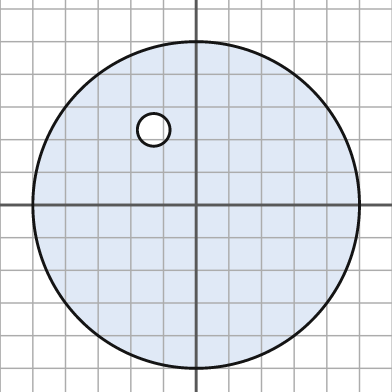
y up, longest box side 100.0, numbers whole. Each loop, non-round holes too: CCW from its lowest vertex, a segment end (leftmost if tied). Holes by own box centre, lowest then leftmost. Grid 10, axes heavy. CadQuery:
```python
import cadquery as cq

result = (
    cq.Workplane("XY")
    .moveTo(0.0, 0.0)
    .circle(50.0)
    .moveTo(-13.0, 23.0)
    .circle(5.0)
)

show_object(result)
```